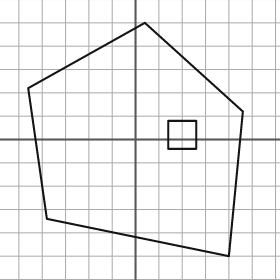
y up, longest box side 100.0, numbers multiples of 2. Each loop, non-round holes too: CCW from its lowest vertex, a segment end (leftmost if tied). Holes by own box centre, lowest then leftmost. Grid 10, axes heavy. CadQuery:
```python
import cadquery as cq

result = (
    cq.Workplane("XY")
    .moveTo(40.0, -50.0)
    .lineTo(46.0, 12.0)
    .lineTo(4.0, 50.0)
    .lineTo(-46.0, 22.0)
    .lineTo(-38.0, -34.0)
    .close()
    .moveTo(14.0, -4.0)
    .lineTo(26.0, -4.0)
    .lineTo(26.0, 8.0)
    .lineTo(14.0, 8.0)
    .close()
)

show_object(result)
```